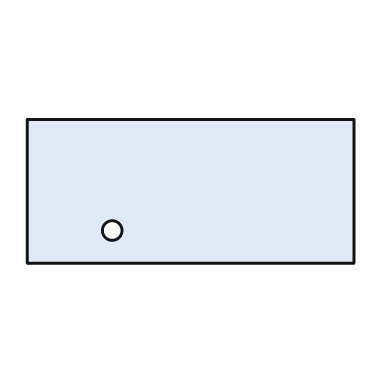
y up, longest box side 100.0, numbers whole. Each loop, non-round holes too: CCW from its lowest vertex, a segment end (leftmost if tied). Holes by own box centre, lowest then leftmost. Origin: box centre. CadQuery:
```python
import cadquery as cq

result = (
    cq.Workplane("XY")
    .moveTo(-50.0, -22.0)
    .lineTo(50.0, -22.0)
    .lineTo(50.0, 22.0)
    .lineTo(-50.0, 22.0)
    .close()
    .moveTo(-24.0, -12.0)
    .circle(3.0)
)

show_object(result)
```